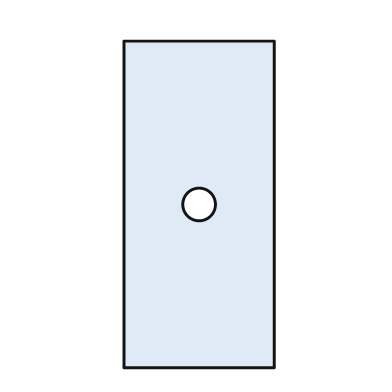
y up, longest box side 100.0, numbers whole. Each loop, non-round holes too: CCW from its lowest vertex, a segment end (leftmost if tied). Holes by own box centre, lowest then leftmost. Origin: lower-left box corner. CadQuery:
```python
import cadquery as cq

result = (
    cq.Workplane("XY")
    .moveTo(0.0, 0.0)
    .lineTo(46.0, 0.0)
    .lineTo(46.0, 100.0)
    .lineTo(0.0, 100.0)
    .close()
    .moveTo(23.0, 50.0)
    .circle(5.0)
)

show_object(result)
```